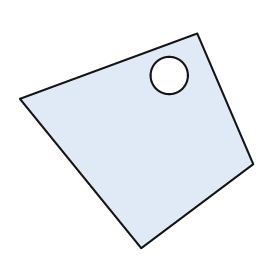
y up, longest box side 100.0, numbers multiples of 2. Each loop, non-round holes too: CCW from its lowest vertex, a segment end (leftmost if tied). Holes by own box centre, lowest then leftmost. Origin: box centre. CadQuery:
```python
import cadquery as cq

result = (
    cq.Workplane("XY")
    .moveTo(2.0, -46.0)
    .lineTo(50.0, -10.0)
    .lineTo(26.0, 46.0)
    .lineTo(-50.0, 18.0)
    .close()
    .moveTo(14.0, 28.0)
    .circle(8.0)
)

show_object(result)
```